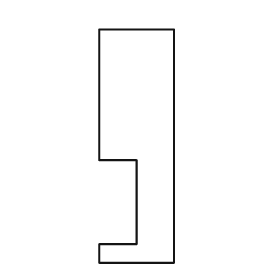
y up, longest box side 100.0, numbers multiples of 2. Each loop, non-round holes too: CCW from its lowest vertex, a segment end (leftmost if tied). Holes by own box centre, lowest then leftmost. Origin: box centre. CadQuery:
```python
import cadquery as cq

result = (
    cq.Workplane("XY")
    .moveTo(-16.0, -50.0)
    .lineTo(16.0, -50.0)
    .lineTo(16.0, 50.0)
    .lineTo(-16.0, 50.0)
    .lineTo(-16.0, -6.0)
    .lineTo(0.0, -6.0)
    .lineTo(0.0, -42.0)
    .lineTo(-16.0, -42.0)
    .close()
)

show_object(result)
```